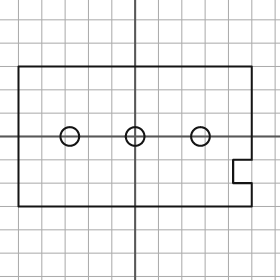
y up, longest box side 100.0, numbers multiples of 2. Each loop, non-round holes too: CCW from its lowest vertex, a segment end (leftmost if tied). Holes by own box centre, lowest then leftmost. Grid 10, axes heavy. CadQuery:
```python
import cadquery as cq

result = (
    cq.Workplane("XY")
    .moveTo(-50.0, -30.0)
    .lineTo(50.0, -30.0)
    .lineTo(50.0, -20.0)
    .lineTo(42.0, -20.0)
    .lineTo(42.0, -10.0)
    .lineTo(50.0, -10.0)
    .lineTo(50.0, 30.0)
    .lineTo(-50.0, 30.0)
    .close()
    .moveTo(-28.0, 0.0)
    .circle(4.0)
    .moveTo(0.0, 0.0)
    .circle(4.0)
    .moveTo(28.0, 0.0)
    .circle(4.0)
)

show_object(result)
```